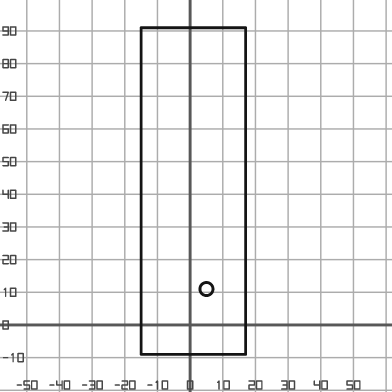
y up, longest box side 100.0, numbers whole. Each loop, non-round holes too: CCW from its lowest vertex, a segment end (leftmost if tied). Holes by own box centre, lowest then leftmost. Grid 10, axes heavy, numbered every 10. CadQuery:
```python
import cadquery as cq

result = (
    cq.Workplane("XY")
    .moveTo(-15.0, -9.0)
    .lineTo(17.0, -9.0)
    .lineTo(17.0, 91.0)
    .lineTo(-15.0, 91.0)
    .close()
    .moveTo(5.0, 11.0)
    .circle(2.0)
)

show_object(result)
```